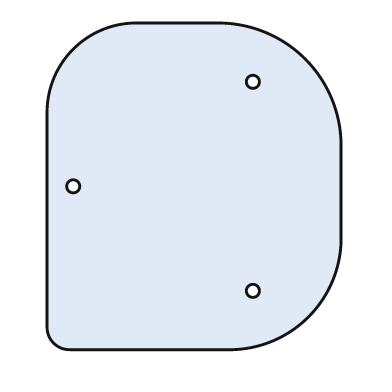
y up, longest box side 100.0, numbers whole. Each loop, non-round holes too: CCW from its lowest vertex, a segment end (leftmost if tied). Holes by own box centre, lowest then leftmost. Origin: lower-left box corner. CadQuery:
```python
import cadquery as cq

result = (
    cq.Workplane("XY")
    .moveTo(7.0, 0.0)
    .lineTo(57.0, 0.0)
    .threePointArc((80.0, 10.0), (90.0, 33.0))
    .lineTo(90.0, 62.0)
    .threePointArc((79.0, 89.0), (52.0, 100.0))
    .lineTo(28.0, 100.0)
    .threePointArc((8.0, 92.0), (0.0, 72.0))
    .lineTo(0.0, 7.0)
    .threePointArc((2.0, 2.0), (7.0, 0.0))
    .close()
    .moveTo(63.0, 18.0)
    .circle(2.0)
    .moveTo(8.0, 50.0)
    .circle(2.0)
    .moveTo(63.0, 82.0)
    .circle(2.0)
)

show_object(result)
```